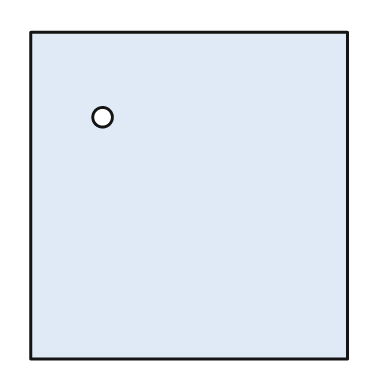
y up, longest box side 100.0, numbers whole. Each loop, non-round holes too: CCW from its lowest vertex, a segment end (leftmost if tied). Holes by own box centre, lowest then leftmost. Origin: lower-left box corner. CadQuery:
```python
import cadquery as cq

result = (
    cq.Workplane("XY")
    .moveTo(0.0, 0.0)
    .lineTo(97.0, 0.0)
    .lineTo(97.0, 100.0)
    .lineTo(0.0, 100.0)
    .close()
    .moveTo(22.0, 74.0)
    .circle(3.0)
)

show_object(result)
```